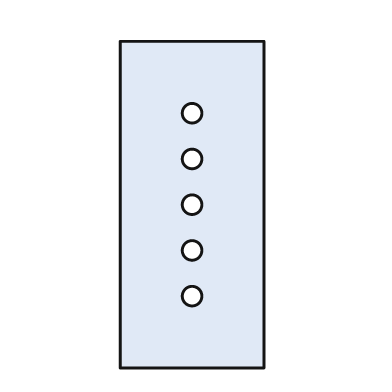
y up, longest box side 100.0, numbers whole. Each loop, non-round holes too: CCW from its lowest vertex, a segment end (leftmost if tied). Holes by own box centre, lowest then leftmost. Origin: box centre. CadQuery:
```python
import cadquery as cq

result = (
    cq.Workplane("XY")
    .moveTo(-22.0, -50.0)
    .lineTo(22.0, -50.0)
    .lineTo(22.0, 50.0)
    .lineTo(-22.0, 50.0)
    .close()
    .moveTo(0.0, -28.0)
    .circle(3.0)
    .moveTo(0.0, -14.0)
    .circle(3.0)
    .moveTo(0.0, 0.0)
    .circle(3.0)
    .moveTo(0.0, 14.0)
    .circle(3.0)
    .moveTo(0.0, 28.0)
    .circle(3.0)
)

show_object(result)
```